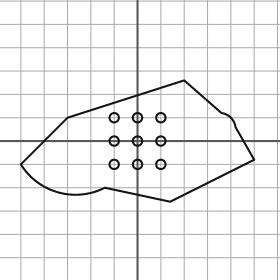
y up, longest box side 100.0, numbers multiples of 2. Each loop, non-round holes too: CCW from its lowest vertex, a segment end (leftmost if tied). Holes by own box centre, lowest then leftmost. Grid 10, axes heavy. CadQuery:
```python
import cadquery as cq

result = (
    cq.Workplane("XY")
    .moveTo(14.0, -26.0)
    .lineTo(50.0, -8.0)
    .lineTo(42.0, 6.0)
    .threePointArc((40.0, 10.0), (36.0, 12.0))
    .lineTo(20.0, 26.0)
    .lineTo(-30.0, 10.0)
    .lineTo(-50.0, -10.0)
    .threePointArc((-34.0, -22.0), (-14.0, -20.0))
    .close()
    .moveTo(-10.0, -10.0)
    .circle(2.0)
    .moveTo(0.0, -10.0)
    .circle(2.0)
    .moveTo(10.0, -10.0)
    .circle(2.0)
    .moveTo(-10.0, 0.0)
    .circle(2.0)
    .moveTo(0.0, 0.0)
    .circle(2.0)
    .moveTo(10.0, 0.0)
    .circle(2.0)
    .moveTo(-10.0, 10.0)
    .circle(2.0)
    .moveTo(0.0, 10.0)
    .circle(2.0)
    .moveTo(10.0, 10.0)
    .circle(2.0)
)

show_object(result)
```